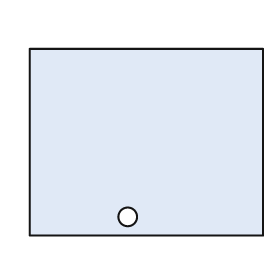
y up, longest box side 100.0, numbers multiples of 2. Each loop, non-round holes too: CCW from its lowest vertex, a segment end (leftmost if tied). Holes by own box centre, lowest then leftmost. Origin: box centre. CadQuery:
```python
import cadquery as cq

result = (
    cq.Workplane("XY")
    .moveTo(-50.0, -40.0)
    .lineTo(50.0, -40.0)
    .lineTo(50.0, 40.0)
    .lineTo(-50.0, 40.0)
    .close()
    .moveTo(-8.0, -32.0)
    .circle(4.0)
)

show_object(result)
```